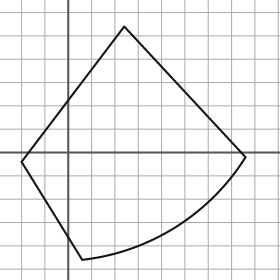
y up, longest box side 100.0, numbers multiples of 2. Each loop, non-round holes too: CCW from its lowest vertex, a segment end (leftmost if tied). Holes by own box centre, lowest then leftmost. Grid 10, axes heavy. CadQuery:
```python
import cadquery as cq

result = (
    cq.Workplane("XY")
    .moveTo(6.0, -46.0)
    .threePointArc((46.0, -32.0), (76.0, -2.0))
    .lineTo(24.0, 54.0)
    .lineTo(-20.0, -4.0)
    .close()
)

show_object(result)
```